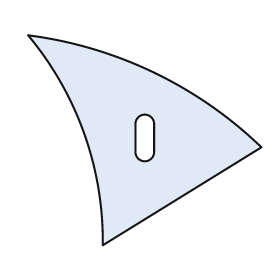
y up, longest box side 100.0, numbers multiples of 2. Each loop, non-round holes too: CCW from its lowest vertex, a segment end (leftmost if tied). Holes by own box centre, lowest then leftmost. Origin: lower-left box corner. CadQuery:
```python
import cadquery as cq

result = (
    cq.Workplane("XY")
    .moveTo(32.0, 0.0)
    .lineTo(100.0, 42.0)
    .threePointArc((54.0, 74.0), (0.0, 90.0))
    .threePointArc((24.0, 48.0), (32.0, 0.0))
    .close()
    .moveTo(46.0, 40.0)
    .threePointArc((50.0, 36.0), (54.0, 40.0))
    .lineTo(54.0, 52.0)
    .threePointArc((50.0, 56.0), (46.0, 52.0))
    .close()
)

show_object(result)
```